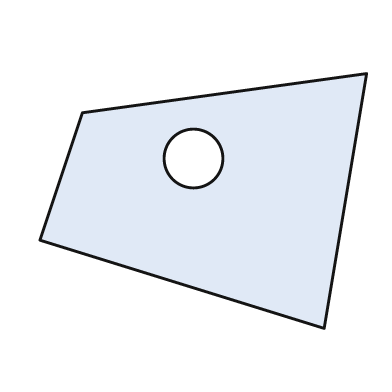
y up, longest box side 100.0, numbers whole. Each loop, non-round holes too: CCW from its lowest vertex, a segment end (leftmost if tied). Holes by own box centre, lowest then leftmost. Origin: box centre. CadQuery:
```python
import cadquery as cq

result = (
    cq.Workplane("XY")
    .moveTo(37.0, -39.0)
    .lineTo(50.0, 39.0)
    .lineTo(-37.0, 27.0)
    .lineTo(-50.0, -12.0)
    .close()
    .moveTo(-3.0, 13.0)
    .circle(9.0)
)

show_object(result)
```